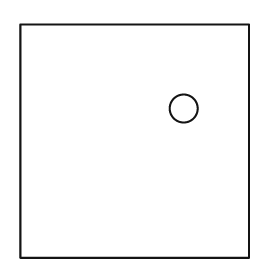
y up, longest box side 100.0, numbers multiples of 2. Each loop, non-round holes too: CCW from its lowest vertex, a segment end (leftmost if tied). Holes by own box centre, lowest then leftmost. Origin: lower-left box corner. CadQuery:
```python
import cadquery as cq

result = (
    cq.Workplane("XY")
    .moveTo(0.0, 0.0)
    .lineTo(98.0, 0.0)
    .lineTo(98.0, 100.0)
    .lineTo(0.0, 100.0)
    .close()
    .moveTo(70.0, 64.0)
    .circle(6.0)
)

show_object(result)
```